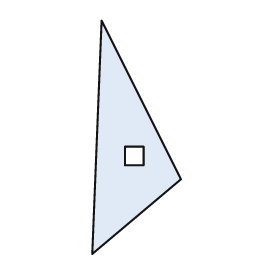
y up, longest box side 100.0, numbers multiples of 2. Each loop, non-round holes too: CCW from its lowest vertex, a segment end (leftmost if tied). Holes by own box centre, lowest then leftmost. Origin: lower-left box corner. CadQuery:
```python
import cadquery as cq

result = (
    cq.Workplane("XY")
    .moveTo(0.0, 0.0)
    .lineTo(38.0, 32.0)
    .lineTo(4.0, 100.0)
    .close()
    .moveTo(14.0, 38.0)
    .lineTo(22.0, 38.0)
    .lineTo(22.0, 46.0)
    .lineTo(14.0, 46.0)
    .close()
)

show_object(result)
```